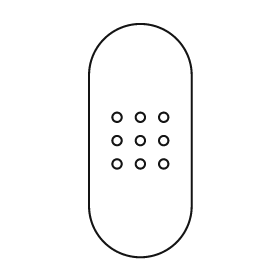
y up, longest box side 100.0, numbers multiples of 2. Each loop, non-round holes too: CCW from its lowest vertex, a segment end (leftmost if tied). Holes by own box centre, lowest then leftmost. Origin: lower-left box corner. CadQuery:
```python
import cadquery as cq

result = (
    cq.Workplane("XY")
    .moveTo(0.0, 22.0)
    .threePointArc((22.0, 0.0), (44.0, 22.0))
    .lineTo(44.0, 78.0)
    .threePointArc((22.0, 100.0), (0.0, 78.0))
    .close()
    .moveTo(12.0, 40.0)
    .circle(2.0)
    .moveTo(22.0, 40.0)
    .circle(2.0)
    .moveTo(32.0, 40.0)
    .circle(2.0)
    .moveTo(12.0, 50.0)
    .circle(2.0)
    .moveTo(22.0, 50.0)
    .circle(2.0)
    .moveTo(32.0, 50.0)
    .circle(2.0)
    .moveTo(12.0, 60.0)
    .circle(2.0)
    .moveTo(22.0, 60.0)
    .circle(2.0)
    .moveTo(32.0, 60.0)
    .circle(2.0)
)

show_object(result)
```